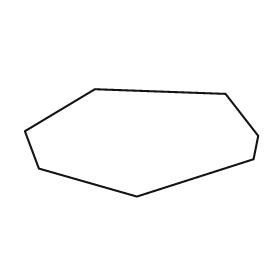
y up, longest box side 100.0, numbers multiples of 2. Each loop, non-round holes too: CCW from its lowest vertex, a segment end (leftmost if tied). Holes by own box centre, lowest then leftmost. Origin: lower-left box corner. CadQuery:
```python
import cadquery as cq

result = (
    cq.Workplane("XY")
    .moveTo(48.0, 0.0)
    .lineTo(98.0, 16.0)
    .lineTo(100.0, 26.0)
    .lineTo(86.0, 44.0)
    .lineTo(30.0, 46.0)
    .lineTo(0.0, 28.0)
    .lineTo(6.0, 12.0)
    .close()
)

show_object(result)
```